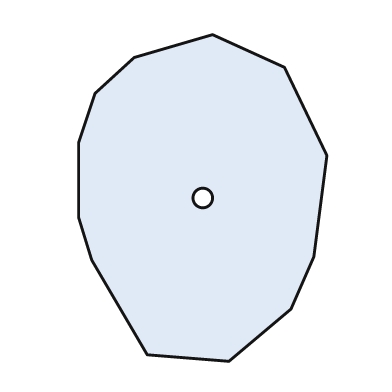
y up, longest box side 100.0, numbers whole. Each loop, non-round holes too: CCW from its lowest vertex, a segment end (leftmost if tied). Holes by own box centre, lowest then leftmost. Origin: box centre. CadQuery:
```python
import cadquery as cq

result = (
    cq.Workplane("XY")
    .moveTo(8.0, -50.0)
    .lineTo(27.0, -34.0)
    .lineTo(34.0, -18.0)
    .lineTo(38.0, 13.0)
    .lineTo(25.0, 40.0)
    .lineTo(3.0, 50.0)
    .lineTo(-21.0, 43.0)
    .lineTo(-33.0, 32.0)
    .lineTo(-38.0, 17.0)
    .lineTo(-38.0, -6.0)
    .lineTo(-34.0, -19.0)
    .lineTo(-17.0, -48.0)
    .close()
    .moveTo(0.0, 0.0)
    .circle(3.0)
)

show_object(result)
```